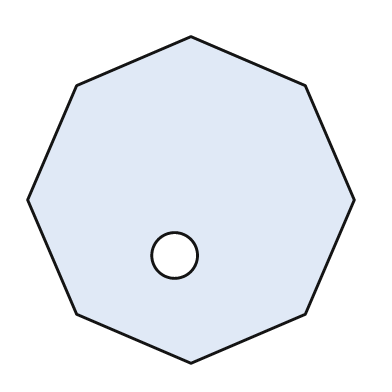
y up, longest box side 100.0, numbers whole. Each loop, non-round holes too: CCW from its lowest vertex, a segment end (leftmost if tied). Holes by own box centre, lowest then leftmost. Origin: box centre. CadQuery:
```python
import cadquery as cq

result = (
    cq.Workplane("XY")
    .moveTo(0.0, -50.0)
    .lineTo(35.0, -35.0)
    .lineTo(50.0, 0.0)
    .lineTo(35.0, 35.0)
    .lineTo(0.0, 50.0)
    .lineTo(-35.0, 35.0)
    .lineTo(-50.0, 0.0)
    .lineTo(-35.0, -35.0)
    .close()
    .moveTo(-5.0, -17.0)
    .circle(7.0)
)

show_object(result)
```